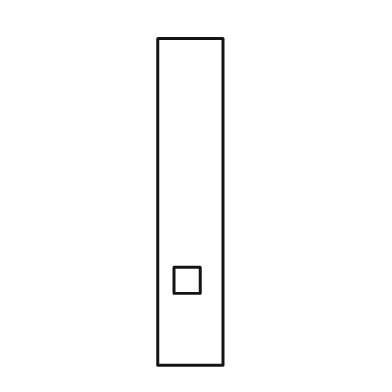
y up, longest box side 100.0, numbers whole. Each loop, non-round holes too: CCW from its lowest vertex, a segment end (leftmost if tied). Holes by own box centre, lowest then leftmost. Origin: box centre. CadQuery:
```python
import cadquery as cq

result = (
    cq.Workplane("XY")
    .moveTo(-10.0, -50.0)
    .lineTo(10.0, -50.0)
    .lineTo(10.0, 50.0)
    .lineTo(-10.0, 50.0)
    .close()
    .moveTo(-5.0, -28.0)
    .lineTo(3.0, -28.0)
    .lineTo(3.0, -20.0)
    .lineTo(-5.0, -20.0)
    .close()
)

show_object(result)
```